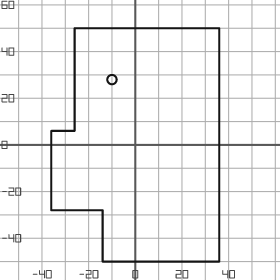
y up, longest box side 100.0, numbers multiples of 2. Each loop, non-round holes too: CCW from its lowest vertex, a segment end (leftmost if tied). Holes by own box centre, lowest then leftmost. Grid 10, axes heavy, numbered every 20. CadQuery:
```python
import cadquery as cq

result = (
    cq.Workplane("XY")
    .moveTo(-14.0, -50.0)
    .lineTo(36.0, -50.0)
    .lineTo(36.0, 50.0)
    .lineTo(-26.0, 50.0)
    .lineTo(-26.0, 6.0)
    .lineTo(-36.0, 6.0)
    .lineTo(-36.0, -28.0)
    .lineTo(-14.0, -28.0)
    .close()
    .moveTo(-10.0, 28.0)
    .circle(2.0)
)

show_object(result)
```